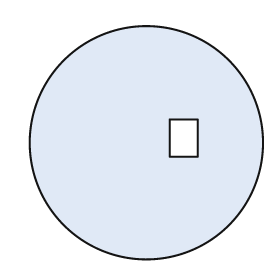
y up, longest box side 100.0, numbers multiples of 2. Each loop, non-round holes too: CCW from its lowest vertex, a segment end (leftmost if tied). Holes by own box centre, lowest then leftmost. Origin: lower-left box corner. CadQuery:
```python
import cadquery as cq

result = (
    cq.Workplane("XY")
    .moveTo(50.0, 50.0)
    .circle(50.0)
    .moveTo(60.0, 44.0)
    .lineTo(72.0, 44.0)
    .lineTo(72.0, 60.0)
    .lineTo(60.0, 60.0)
    .close()
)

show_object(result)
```